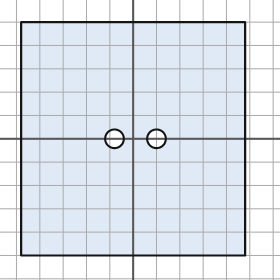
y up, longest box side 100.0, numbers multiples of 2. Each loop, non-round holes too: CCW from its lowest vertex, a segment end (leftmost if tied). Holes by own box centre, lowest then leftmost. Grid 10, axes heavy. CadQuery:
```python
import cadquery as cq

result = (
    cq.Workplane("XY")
    .moveTo(-48.0, -50.0)
    .lineTo(48.0, -50.0)
    .lineTo(48.0, 50.0)
    .lineTo(-48.0, 50.0)
    .close()
    .moveTo(-8.0, 0.0)
    .circle(4.0)
    .moveTo(10.0, 0.0)
    .circle(4.0)
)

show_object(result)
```